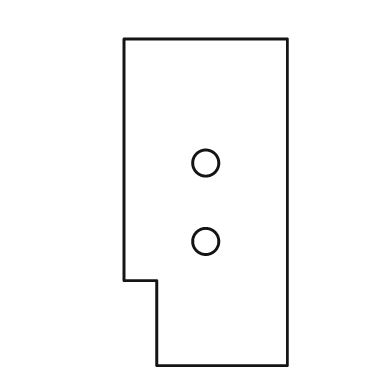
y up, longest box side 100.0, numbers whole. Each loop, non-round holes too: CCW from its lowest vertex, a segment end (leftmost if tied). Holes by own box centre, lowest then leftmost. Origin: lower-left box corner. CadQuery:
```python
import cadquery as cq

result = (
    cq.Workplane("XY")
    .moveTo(10.0, 0.0)
    .lineTo(50.0, 0.0)
    .lineTo(50.0, 100.0)
    .lineTo(0.0, 100.0)
    .lineTo(0.0, 26.0)
    .lineTo(10.0, 26.0)
    .close()
    .moveTo(25.0, 38.0)
    .circle(4.0)
    .moveTo(25.0, 62.0)
    .circle(4.0)
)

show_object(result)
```